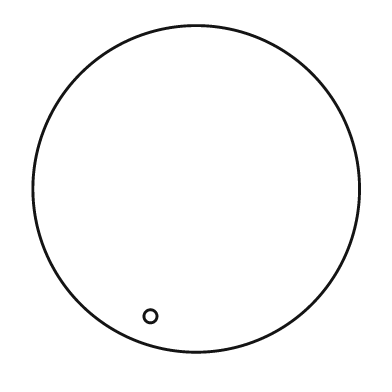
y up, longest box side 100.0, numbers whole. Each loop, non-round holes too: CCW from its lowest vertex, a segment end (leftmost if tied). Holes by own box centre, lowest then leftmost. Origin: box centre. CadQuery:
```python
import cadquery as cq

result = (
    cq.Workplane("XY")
    .moveTo(0.0, 0.0)
    .circle(50.0)
    .moveTo(-14.0, -39.0)
    .circle(2.0)
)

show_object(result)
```